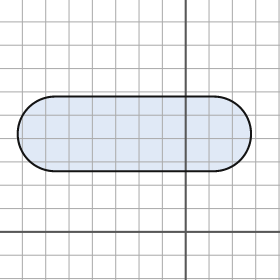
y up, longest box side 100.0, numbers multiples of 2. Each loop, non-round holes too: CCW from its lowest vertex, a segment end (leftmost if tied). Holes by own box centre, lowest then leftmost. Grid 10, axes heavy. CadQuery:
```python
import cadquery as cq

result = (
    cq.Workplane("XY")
    .moveTo(-56.0, 26.0)
    .lineTo(12.0, 26.0)
    .threePointArc((28.0, 42.0), (12.0, 58.0))
    .lineTo(-56.0, 58.0)
    .threePointArc((-72.0, 42.0), (-56.0, 26.0))
    .close()
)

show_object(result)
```